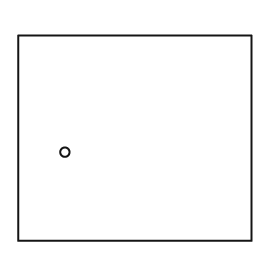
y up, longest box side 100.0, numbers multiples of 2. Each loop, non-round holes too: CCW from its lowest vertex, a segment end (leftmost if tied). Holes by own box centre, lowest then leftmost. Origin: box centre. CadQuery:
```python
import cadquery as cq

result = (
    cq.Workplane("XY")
    .moveTo(-50.0, -44.0)
    .lineTo(50.0, -44.0)
    .lineTo(50.0, 44.0)
    .lineTo(-50.0, 44.0)
    .close()
    .moveTo(-30.0, -6.0)
    .circle(2.0)
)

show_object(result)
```